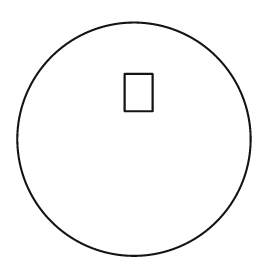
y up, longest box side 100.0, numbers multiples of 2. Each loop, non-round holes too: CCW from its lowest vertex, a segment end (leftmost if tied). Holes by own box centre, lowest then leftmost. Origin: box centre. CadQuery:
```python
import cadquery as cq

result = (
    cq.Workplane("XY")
    .moveTo(0.0, 0.0)
    .circle(50.0)
    .moveTo(-4.0, 12.0)
    .lineTo(8.0, 12.0)
    .lineTo(8.0, 28.0)
    .lineTo(-4.0, 28.0)
    .close()
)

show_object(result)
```